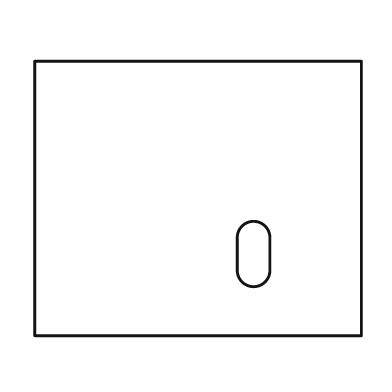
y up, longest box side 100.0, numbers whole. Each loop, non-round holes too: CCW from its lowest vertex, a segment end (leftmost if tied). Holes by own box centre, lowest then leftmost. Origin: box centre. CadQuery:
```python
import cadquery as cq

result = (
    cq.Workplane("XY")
    .moveTo(-50.0, -42.0)
    .lineTo(50.0, -42.0)
    .lineTo(50.0, 42.0)
    .lineTo(-50.0, 42.0)
    .close()
    .moveTo(12.0, -22.0)
    .threePointArc((17.0, -27.0), (22.0, -22.0))
    .lineTo(22.0, -12.0)
    .threePointArc((17.0, -7.0), (12.0, -12.0))
    .close()
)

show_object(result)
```